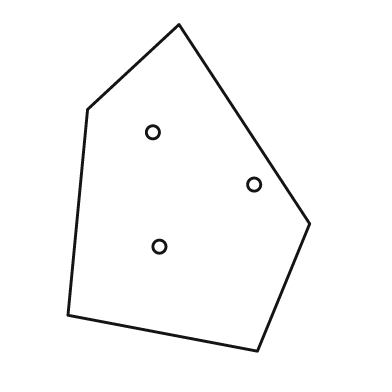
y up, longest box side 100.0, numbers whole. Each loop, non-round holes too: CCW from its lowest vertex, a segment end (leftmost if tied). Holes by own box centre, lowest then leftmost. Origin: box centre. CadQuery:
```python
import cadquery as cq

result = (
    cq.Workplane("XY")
    .moveTo(21.0, -50.0)
    .lineTo(37.0, -11.0)
    .lineTo(-3.0, 50.0)
    .lineTo(-31.0, 24.0)
    .lineTo(-37.0, -39.0)
    .close()
    .moveTo(-9.0, -18.0)
    .circle(2.0)
    .moveTo(20.0, 1.0)
    .circle(2.0)
    .moveTo(-11.0, 17.0)
    .circle(2.0)
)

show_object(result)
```